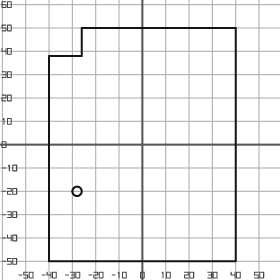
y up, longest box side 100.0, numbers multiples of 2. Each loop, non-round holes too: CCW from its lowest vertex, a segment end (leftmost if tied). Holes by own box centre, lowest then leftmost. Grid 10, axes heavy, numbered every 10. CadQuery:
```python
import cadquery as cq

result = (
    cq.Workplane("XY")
    .moveTo(-40.0, -50.0)
    .lineTo(40.0, -50.0)
    .lineTo(40.0, 50.0)
    .lineTo(-26.0, 50.0)
    .lineTo(-26.0, 38.0)
    .lineTo(-40.0, 38.0)
    .close()
    .moveTo(-28.0, -20.0)
    .circle(2.0)
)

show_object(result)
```